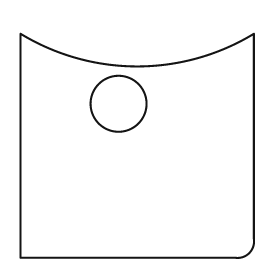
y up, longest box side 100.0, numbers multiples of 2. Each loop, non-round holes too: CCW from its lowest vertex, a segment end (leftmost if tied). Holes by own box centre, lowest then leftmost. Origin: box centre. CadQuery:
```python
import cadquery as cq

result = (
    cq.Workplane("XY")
    .moveTo(-50.0, -48.0)
    .lineTo(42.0, -48.0)
    .threePointArc((48.0, -46.0), (50.0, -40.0))
    .lineTo(50.0, 48.0)
    .threePointArc((0.0, 34.0), (-50.0, 48.0))
    .close()
    .moveTo(-8.0, 18.0)
    .circle(12.0)
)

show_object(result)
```